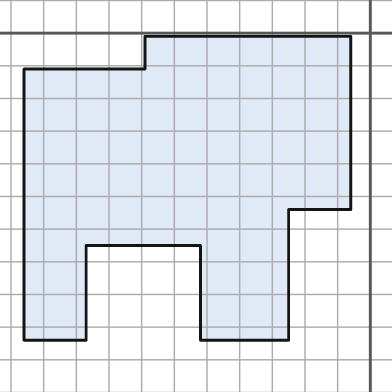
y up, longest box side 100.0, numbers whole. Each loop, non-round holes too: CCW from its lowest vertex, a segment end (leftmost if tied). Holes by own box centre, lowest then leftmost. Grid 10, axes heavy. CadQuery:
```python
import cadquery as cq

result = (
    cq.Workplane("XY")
    .moveTo(-106.0, -94.0)
    .lineTo(-87.0, -94.0)
    .lineTo(-87.0, -65.0)
    .lineTo(-52.0, -65.0)
    .lineTo(-52.0, -94.0)
    .lineTo(-25.0, -94.0)
    .lineTo(-25.0, -54.0)
    .lineTo(-6.0, -54.0)
    .lineTo(-6.0, -1.0)
    .lineTo(-69.0, -1.0)
    .lineTo(-69.0, -11.0)
    .lineTo(-106.0, -11.0)
    .close()
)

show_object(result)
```